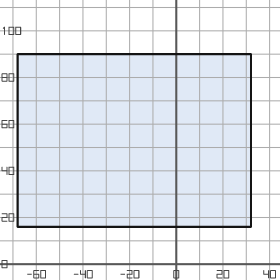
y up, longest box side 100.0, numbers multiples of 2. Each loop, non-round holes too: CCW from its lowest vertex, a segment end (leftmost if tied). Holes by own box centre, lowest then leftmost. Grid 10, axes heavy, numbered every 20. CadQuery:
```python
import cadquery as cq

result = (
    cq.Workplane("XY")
    .moveTo(-68.0, 16.0)
    .lineTo(32.0, 16.0)
    .lineTo(32.0, 90.0)
    .lineTo(-68.0, 90.0)
    .close()
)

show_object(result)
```